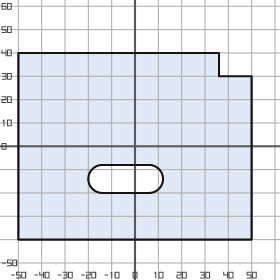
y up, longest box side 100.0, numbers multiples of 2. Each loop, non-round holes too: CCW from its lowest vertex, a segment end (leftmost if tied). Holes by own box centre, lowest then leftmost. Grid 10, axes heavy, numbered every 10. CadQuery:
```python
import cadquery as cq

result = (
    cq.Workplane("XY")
    .moveTo(-50.0, -40.0)
    .lineTo(50.0, -40.0)
    .lineTo(50.0, 30.0)
    .lineTo(36.0, 30.0)
    .lineTo(36.0, 40.0)
    .lineTo(-50.0, 40.0)
    .close()
    .moveTo(-14.0, -20.0)
    .lineTo(6.0, -20.0)
    .threePointArc((12.0, -14.0), (6.0, -8.0))
    .lineTo(-14.0, -8.0)
    .threePointArc((-20.0, -14.0), (-14.0, -20.0))
    .close()
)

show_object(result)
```